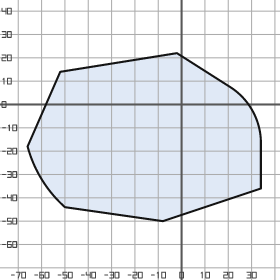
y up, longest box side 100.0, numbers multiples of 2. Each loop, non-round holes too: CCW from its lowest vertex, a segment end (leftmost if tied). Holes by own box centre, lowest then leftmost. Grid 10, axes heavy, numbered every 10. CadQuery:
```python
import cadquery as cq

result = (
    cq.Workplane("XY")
    .moveTo(-8.0, -50.0)
    .lineTo(34.0, -36.0)
    .lineTo(34.0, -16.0)
    .threePointArc((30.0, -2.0), (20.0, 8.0))
    .lineTo(-2.0, 22.0)
    .lineTo(-52.0, 14.0)
    .lineTo(-66.0, -18.0)
    .threePointArc((-60.0, -32.0), (-50.0, -44.0))
    .close()
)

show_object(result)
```